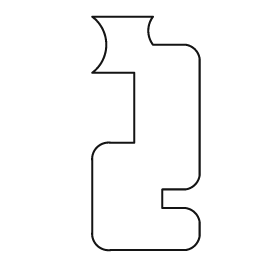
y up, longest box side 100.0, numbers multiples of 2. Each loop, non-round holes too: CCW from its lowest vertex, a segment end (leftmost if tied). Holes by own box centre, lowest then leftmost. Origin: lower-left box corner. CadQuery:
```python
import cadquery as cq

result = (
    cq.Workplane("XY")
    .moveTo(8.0, 0.0)
    .lineTo(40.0, 0.0)
    .threePointArc((44.0, 2.0), (46.0, 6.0))
    .lineTo(46.0, 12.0)
    .threePointArc((44.0, 16.0), (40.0, 18.0))
    .lineTo(30.0, 18.0)
    .lineTo(30.0, 26.0)
    .lineTo(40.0, 26.0)
    .threePointArc((44.0, 28.0), (46.0, 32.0))
    .lineTo(46.0, 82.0)
    .threePointArc((44.0, 86.0), (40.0, 88.0))
    .lineTo(26.0, 88.0)
    .threePointArc((24.0, 94.0), (26.0, 100.0))
    .lineTo(0.0, 100.0)
    .threePointArc((6.0, 88.0), (0.0, 76.0))
    .lineTo(18.0, 76.0)
    .lineTo(18.0, 46.0)
    .lineTo(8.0, 46.0)
    .threePointArc((2.0, 44.0), (0.0, 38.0))
    .lineTo(0.0, 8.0)
    .threePointArc((2.0, 2.0), (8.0, 0.0))
    .close()
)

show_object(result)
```